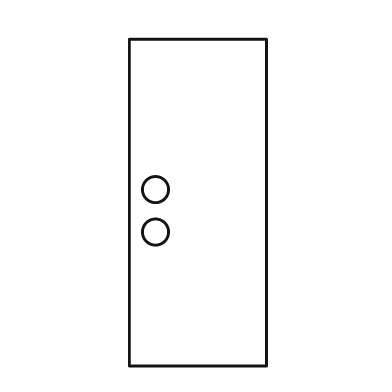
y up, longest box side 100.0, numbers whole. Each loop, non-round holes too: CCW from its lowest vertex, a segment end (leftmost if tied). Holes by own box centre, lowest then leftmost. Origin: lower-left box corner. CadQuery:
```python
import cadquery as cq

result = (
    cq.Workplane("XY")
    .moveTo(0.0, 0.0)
    .lineTo(42.0, 0.0)
    .lineTo(42.0, 100.0)
    .lineTo(0.0, 100.0)
    .close()
    .moveTo(8.0, 41.0)
    .circle(4.0)
    .moveTo(8.0, 54.0)
    .circle(4.0)
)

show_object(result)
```